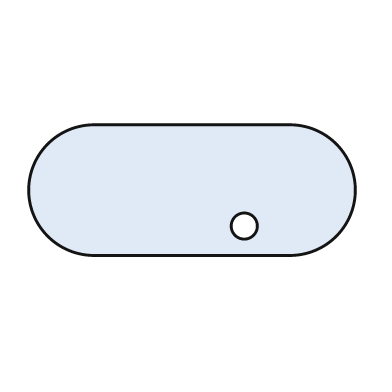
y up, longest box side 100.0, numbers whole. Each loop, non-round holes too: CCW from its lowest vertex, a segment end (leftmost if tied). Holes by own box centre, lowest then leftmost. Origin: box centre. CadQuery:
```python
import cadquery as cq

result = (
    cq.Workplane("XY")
    .moveTo(-30.0, -20.0)
    .lineTo(30.0, -20.0)
    .threePointArc((50.0, 0.0), (30.0, 20.0))
    .lineTo(-30.0, 20.0)
    .threePointArc((-50.0, 0.0), (-30.0, -20.0))
    .close()
    .moveTo(16.0, -11.0)
    .circle(4.0)
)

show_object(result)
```